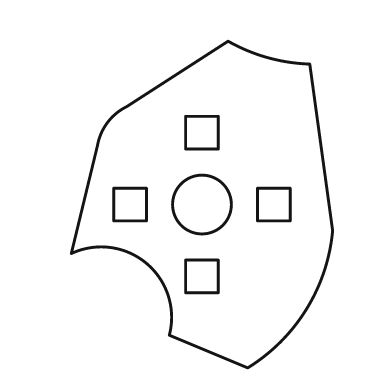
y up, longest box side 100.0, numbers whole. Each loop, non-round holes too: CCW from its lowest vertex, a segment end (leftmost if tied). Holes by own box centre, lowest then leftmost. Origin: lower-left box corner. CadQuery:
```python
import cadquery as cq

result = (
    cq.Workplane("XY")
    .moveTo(54.0, 0.0)
    .threePointArc((72.0, 18.0), (80.0, 42.0))
    .lineTo(73.0, 93.0)
    .threePointArc((60.0, 95.0), (48.0, 100.0))
    .lineTo(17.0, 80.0)
    .threePointArc((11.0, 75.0), (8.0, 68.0))
    .lineTo(0.0, 35.0)
    .threePointArc((23.0, 32.0), (30.0, 10.0))
    .close()
    .moveTo(35.0, 23.0)
    .lineTo(45.0, 23.0)
    .lineTo(45.0, 33.0)
    .lineTo(35.0, 33.0)
    .close()
    .moveTo(13.0, 45.0)
    .lineTo(23.0, 45.0)
    .lineTo(23.0, 55.0)
    .lineTo(13.0, 55.0)
    .close()
    .moveTo(40.0, 50.0)
    .circle(9.0)
    .moveTo(57.0, 45.0)
    .lineTo(67.0, 45.0)
    .lineTo(67.0, 55.0)
    .lineTo(57.0, 55.0)
    .close()
    .moveTo(35.0, 67.0)
    .lineTo(45.0, 67.0)
    .lineTo(45.0, 77.0)
    .lineTo(35.0, 77.0)
    .close()
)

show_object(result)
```